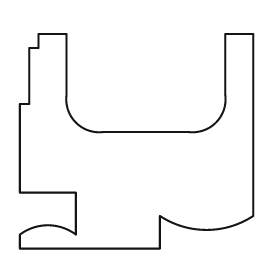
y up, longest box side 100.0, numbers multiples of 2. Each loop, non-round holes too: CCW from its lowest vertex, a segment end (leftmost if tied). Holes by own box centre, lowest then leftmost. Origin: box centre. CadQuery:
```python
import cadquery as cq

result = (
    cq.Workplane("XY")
    .moveTo(-50.0, -46.0)
    .lineTo(10.0, -46.0)
    .lineTo(10.0, -32.0)
    .threePointArc((30.0, -38.0), (50.0, -32.0))
    .lineTo(50.0, 46.0)
    .lineTo(38.0, 46.0)
    .lineTo(38.0, 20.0)
    .threePointArc((34.0, 8.0), (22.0, 4.0))
    .lineTo(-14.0, 4.0)
    .threePointArc((-26.0, 8.0), (-30.0, 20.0))
    .lineTo(-30.0, 46.0)
    .lineTo(-42.0, 46.0)
    .lineTo(-42.0, 40.0)
    .lineTo(-46.0, 40.0)
    .lineTo(-46.0, 16.0)
    .lineTo(-50.0, 16.0)
    .lineTo(-50.0, -22.0)
    .lineTo(-26.0, -22.0)
    .lineTo(-26.0, -40.0)
    .threePointArc((-38.0, -36.0), (-50.0, -40.0))
    .close()
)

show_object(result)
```